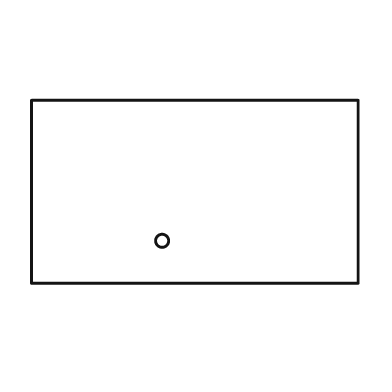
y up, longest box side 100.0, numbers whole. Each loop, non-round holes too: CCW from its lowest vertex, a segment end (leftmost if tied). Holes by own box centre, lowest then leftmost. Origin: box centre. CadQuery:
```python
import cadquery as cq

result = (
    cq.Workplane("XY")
    .moveTo(-50.0, -28.0)
    .lineTo(50.0, -28.0)
    .lineTo(50.0, 28.0)
    .lineTo(-50.0, 28.0)
    .close()
    .moveTo(-10.0, -15.0)
    .circle(2.0)
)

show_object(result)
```